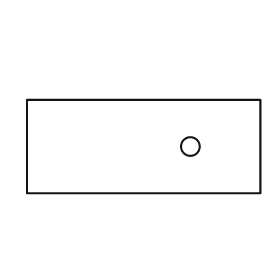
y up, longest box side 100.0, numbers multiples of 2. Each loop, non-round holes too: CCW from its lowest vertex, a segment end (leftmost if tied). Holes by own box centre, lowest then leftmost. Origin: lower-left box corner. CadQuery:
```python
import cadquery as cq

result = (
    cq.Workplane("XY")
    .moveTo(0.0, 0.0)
    .lineTo(100.0, 0.0)
    .lineTo(100.0, 40.0)
    .lineTo(0.0, 40.0)
    .close()
    .moveTo(70.0, 20.0)
    .circle(4.0)
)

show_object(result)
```